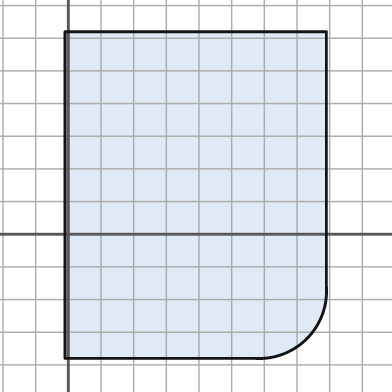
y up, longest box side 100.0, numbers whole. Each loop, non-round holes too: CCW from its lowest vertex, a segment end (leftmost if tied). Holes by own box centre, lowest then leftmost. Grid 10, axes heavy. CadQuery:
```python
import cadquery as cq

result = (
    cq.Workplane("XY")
    .moveTo(-1.0, -38.0)
    .lineTo(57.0, -38.0)
    .threePointArc((73.0, -32.0), (79.0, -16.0))
    .lineTo(79.0, 62.0)
    .lineTo(-1.0, 62.0)
    .close()
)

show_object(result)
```